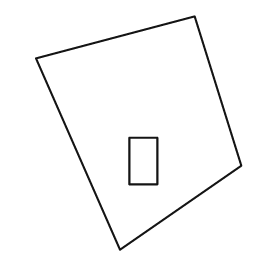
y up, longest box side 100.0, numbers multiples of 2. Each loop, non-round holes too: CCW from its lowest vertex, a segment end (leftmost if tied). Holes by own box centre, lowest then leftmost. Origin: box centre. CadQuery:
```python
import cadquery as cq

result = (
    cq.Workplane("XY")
    .moveTo(-8.0, -50.0)
    .lineTo(44.0, -14.0)
    .lineTo(24.0, 50.0)
    .lineTo(-44.0, 32.0)
    .close()
    .moveTo(-4.0, -22.0)
    .lineTo(8.0, -22.0)
    .lineTo(8.0, -2.0)
    .lineTo(-4.0, -2.0)
    .close()
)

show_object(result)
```